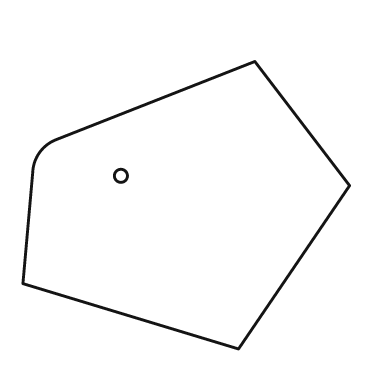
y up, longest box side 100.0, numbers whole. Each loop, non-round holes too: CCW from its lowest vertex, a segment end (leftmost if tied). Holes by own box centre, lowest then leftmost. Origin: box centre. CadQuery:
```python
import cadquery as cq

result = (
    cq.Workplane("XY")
    .moveTo(16.0, -44.0)
    .lineTo(50.0, 6.0)
    .lineTo(21.0, 44.0)
    .lineTo(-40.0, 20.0)
    .threePointArc((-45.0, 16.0), (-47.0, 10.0))
    .lineTo(-50.0, -24.0)
    .close()
    .moveTo(-20.0, 9.0)
    .circle(2.0)
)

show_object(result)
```